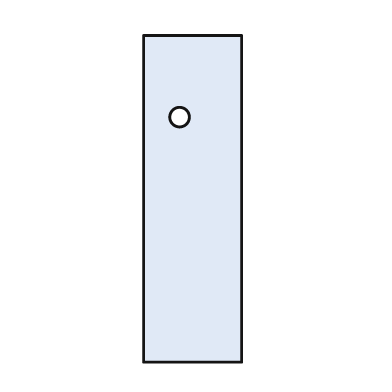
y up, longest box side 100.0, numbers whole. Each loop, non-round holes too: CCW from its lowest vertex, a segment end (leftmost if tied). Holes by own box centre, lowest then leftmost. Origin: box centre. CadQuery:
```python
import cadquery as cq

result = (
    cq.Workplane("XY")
    .moveTo(-15.0, -50.0)
    .lineTo(15.0, -50.0)
    .lineTo(15.0, 50.0)
    .lineTo(-15.0, 50.0)
    .close()
    .moveTo(-4.0, 25.0)
    .circle(3.0)
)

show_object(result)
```